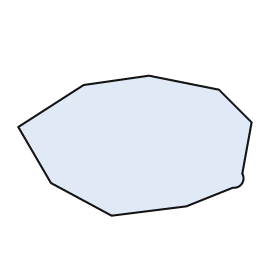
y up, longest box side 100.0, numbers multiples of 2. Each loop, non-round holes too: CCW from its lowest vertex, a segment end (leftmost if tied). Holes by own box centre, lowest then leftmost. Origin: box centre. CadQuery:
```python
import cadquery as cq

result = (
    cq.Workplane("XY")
    .moveTo(-10.0, -30.0)
    .lineTo(22.0, -26.0)
    .lineTo(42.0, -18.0)
    .threePointArc((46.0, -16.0), (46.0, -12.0))
    .lineTo(50.0, 10.0)
    .lineTo(36.0, 24.0)
    .lineTo(6.0, 30.0)
    .lineTo(-22.0, 26.0)
    .lineTo(-50.0, 8.0)
    .lineTo(-36.0, -16.0)
    .close()
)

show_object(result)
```